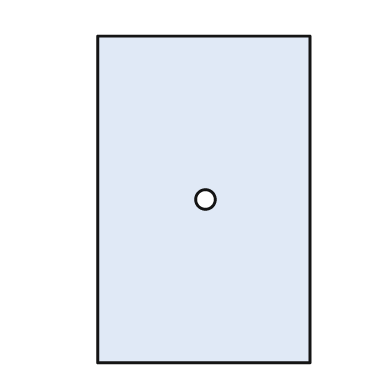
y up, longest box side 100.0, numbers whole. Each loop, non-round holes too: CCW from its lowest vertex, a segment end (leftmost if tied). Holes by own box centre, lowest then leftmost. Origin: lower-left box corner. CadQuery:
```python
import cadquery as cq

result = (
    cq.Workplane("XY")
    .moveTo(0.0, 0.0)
    .lineTo(65.0, 0.0)
    .lineTo(65.0, 100.0)
    .lineTo(0.0, 100.0)
    .close()
    .moveTo(33.0, 50.0)
    .circle(3.0)
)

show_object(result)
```